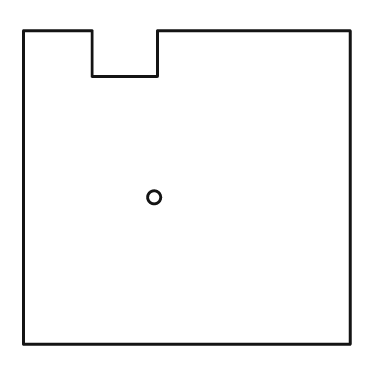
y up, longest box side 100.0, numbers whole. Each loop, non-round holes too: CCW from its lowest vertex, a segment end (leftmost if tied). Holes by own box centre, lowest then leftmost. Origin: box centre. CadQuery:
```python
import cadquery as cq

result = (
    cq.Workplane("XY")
    .moveTo(-50.0, -48.0)
    .lineTo(50.0, -48.0)
    .lineTo(50.0, 48.0)
    .lineTo(-9.0, 48.0)
    .lineTo(-9.0, 34.0)
    .lineTo(-29.0, 34.0)
    .lineTo(-29.0, 48.0)
    .lineTo(-50.0, 48.0)
    .close()
    .moveTo(-10.0, -3.0)
    .circle(2.0)
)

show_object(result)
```